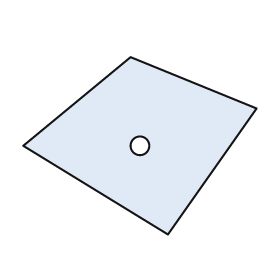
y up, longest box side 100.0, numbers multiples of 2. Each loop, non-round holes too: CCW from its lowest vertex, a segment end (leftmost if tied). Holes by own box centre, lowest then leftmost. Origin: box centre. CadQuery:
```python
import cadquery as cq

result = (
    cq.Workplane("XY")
    .moveTo(12.0, -38.0)
    .lineTo(50.0, 16.0)
    .lineTo(-4.0, 38.0)
    .lineTo(-50.0, 0.0)
    .close()
    .moveTo(0.0, 0.0)
    .circle(4.0)
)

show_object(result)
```